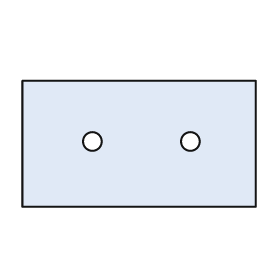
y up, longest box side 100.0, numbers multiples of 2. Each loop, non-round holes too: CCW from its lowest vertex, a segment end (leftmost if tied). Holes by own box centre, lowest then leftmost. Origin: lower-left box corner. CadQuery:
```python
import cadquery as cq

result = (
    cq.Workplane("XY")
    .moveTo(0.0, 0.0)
    .lineTo(100.0, 0.0)
    .lineTo(100.0, 54.0)
    .lineTo(0.0, 54.0)
    .close()
    .moveTo(30.0, 28.0)
    .circle(4.0)
    .moveTo(72.0, 28.0)
    .circle(4.0)
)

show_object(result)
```